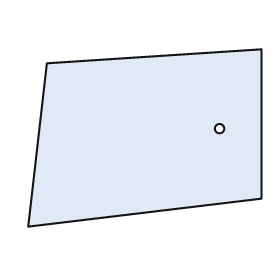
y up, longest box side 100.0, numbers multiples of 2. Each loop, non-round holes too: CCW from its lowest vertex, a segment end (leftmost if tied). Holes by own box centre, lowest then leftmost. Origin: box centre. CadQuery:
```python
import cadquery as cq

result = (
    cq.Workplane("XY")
    .moveTo(-50.0, -38.0)
    .lineTo(50.0, -26.0)
    .lineTo(50.0, 38.0)
    .lineTo(-42.0, 32.0)
    .close()
    .moveTo(32.0, 4.0)
    .circle(2.0)
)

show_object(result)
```